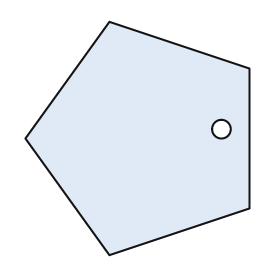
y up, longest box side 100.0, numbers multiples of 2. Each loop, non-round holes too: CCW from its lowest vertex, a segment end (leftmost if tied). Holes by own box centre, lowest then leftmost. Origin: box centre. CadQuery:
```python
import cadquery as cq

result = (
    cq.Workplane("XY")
    .moveTo(-12.0, -50.0)
    .lineTo(48.0, -30.0)
    .lineTo(48.0, 30.0)
    .lineTo(-12.0, 50.0)
    .lineTo(-48.0, 0.0)
    .close()
    .moveTo(36.0, 4.0)
    .circle(4.0)
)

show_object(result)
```